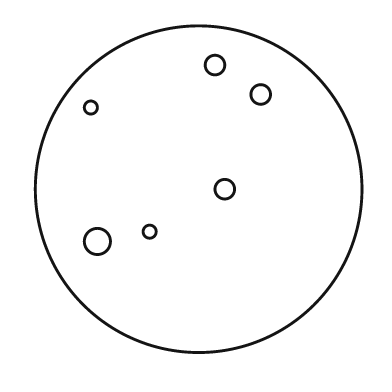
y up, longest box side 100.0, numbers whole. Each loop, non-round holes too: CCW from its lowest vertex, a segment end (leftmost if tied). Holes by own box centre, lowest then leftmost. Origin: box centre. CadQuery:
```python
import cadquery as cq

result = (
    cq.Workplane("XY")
    .moveTo(0.0, 0.0)
    .circle(50.0)
    .moveTo(-31.0, -16.0)
    .circle(4.0)
    .moveTo(-15.0, -13.0)
    .circle(2.0)
    .moveTo(8.0, 0.0)
    .circle(3.0)
    .moveTo(-33.0, 25.0)
    .circle(2.0)
    .moveTo(19.0, 29.0)
    .circle(3.0)
    .moveTo(5.0, 38.0)
    .circle(3.0)
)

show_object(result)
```